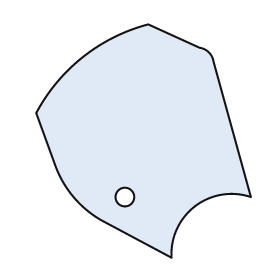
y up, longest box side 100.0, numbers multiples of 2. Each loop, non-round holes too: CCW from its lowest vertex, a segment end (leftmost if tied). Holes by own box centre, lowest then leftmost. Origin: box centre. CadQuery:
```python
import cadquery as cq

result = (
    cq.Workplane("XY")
    .moveTo(12.0, -50.0)
    .threePointArc((22.0, -28.0), (46.0, -24.0))
    .lineTo(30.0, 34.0)
    .threePointArc((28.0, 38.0), (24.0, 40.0))
    .lineTo(2.0, 50.0)
    .threePointArc((-26.0, 36.0), (-46.0, 12.0))
    .lineTo(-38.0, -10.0)
    .threePointArc((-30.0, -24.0), (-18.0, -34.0))
    .close()
    .moveTo(-8.0, -24.0)
    .circle(4.0)
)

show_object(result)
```